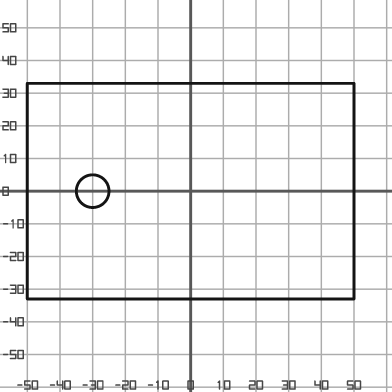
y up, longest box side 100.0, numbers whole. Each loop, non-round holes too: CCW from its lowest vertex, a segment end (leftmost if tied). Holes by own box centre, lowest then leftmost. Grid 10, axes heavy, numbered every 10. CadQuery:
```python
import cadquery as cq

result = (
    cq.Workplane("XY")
    .moveTo(-50.0, -33.0)
    .lineTo(50.0, -33.0)
    .lineTo(50.0, 33.0)
    .lineTo(-50.0, 33.0)
    .close()
    .moveTo(-30.0, 0.0)
    .circle(5.0)
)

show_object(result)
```